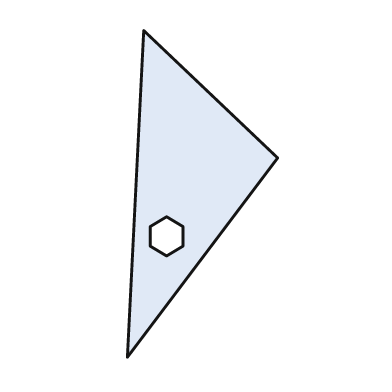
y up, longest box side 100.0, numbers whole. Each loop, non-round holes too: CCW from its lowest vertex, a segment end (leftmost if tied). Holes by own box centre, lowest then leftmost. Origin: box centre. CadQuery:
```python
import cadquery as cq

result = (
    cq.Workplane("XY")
    .moveTo(-23.0, -50.0)
    .lineTo(23.0, 11.0)
    .lineTo(-18.0, 50.0)
    .close()
    .moveTo(-11.0, -19.0)
    .lineTo(-6.0, -16.0)
    .lineTo(-6.0, -10.0)
    .lineTo(-11.0, -7.0)
    .lineTo(-16.0, -10.0)
    .lineTo(-16.0, -16.0)
    .close()
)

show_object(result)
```